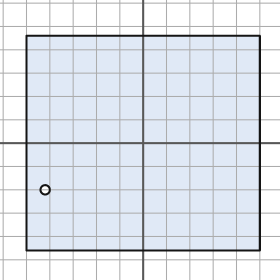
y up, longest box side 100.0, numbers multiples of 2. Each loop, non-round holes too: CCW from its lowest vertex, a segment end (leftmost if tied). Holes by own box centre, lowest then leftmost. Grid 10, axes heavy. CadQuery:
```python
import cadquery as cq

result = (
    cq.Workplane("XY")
    .moveTo(-50.0, -46.0)
    .lineTo(50.0, -46.0)
    .lineTo(50.0, 46.0)
    .lineTo(-50.0, 46.0)
    .close()
    .moveTo(-42.0, -20.0)
    .circle(2.0)
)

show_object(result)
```